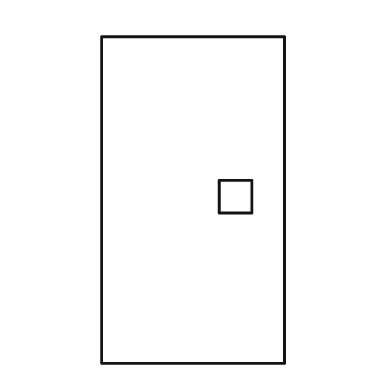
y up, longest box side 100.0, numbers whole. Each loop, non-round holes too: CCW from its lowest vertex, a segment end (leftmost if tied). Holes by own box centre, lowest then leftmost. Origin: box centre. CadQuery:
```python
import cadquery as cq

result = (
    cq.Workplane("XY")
    .moveTo(-28.0, -50.0)
    .lineTo(28.0, -50.0)
    .lineTo(28.0, 50.0)
    .lineTo(-28.0, 50.0)
    .close()
    .moveTo(8.0, -4.0)
    .lineTo(18.0, -4.0)
    .lineTo(18.0, 6.0)
    .lineTo(8.0, 6.0)
    .close()
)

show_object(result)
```